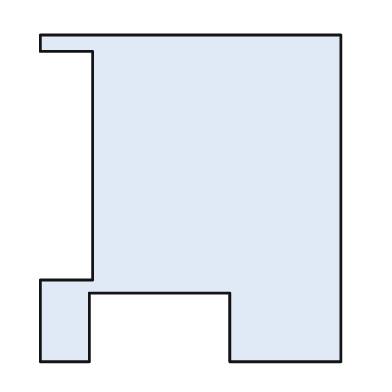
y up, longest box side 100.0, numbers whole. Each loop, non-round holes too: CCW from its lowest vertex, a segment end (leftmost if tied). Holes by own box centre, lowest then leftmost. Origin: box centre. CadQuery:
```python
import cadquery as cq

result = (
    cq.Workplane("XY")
    .moveTo(-46.0, -50.0)
    .lineTo(-31.0, -50.0)
    .lineTo(-31.0, -29.0)
    .lineTo(12.0, -29.0)
    .lineTo(12.0, -50.0)
    .lineTo(46.0, -50.0)
    .lineTo(46.0, 50.0)
    .lineTo(-46.0, 50.0)
    .lineTo(-46.0, 45.0)
    .lineTo(-30.0, 45.0)
    .lineTo(-30.0, -25.0)
    .lineTo(-46.0, -25.0)
    .close()
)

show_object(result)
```